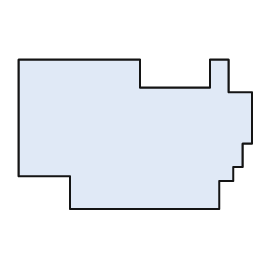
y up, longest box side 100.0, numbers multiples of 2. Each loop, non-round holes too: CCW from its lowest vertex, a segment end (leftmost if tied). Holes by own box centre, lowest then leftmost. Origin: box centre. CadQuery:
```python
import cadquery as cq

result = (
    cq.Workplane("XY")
    .moveTo(-28.0, -32.0)
    .lineTo(36.0, -32.0)
    .lineTo(36.0, -20.0)
    .lineTo(42.0, -20.0)
    .lineTo(42.0, -14.0)
    .lineTo(46.0, -14.0)
    .lineTo(46.0, -4.0)
    .lineTo(50.0, -4.0)
    .lineTo(50.0, 18.0)
    .lineTo(40.0, 18.0)
    .lineTo(40.0, 32.0)
    .lineTo(32.0, 32.0)
    .lineTo(32.0, 20.0)
    .lineTo(2.0, 20.0)
    .lineTo(2.0, 32.0)
    .lineTo(-50.0, 32.0)
    .lineTo(-50.0, -18.0)
    .lineTo(-28.0, -18.0)
    .close()
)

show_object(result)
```